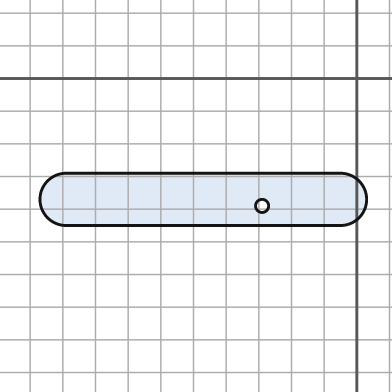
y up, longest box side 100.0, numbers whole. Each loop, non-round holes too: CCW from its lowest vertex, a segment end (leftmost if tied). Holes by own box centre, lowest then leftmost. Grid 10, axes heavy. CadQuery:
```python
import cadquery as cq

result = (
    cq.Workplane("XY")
    .moveTo(-89.0, -45.0)
    .lineTo(-5.0, -45.0)
    .threePointArc((3.0, -37.0), (-5.0, -29.0))
    .lineTo(-89.0, -29.0)
    .threePointArc((-97.0, -37.0), (-89.0, -45.0))
    .close()
    .moveTo(-29.0, -39.0)
    .circle(2.0)
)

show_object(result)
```